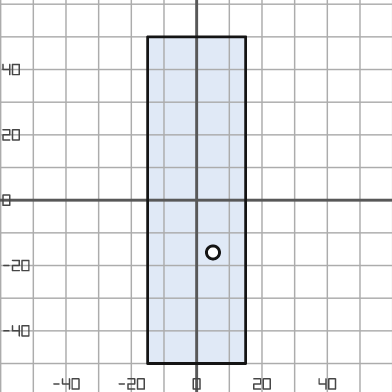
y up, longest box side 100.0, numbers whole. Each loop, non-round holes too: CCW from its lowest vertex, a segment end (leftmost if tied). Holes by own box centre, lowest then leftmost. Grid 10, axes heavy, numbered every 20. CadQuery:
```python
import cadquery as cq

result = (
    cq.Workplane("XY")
    .moveTo(-15.0, -50.0)
    .lineTo(15.0, -50.0)
    .lineTo(15.0, 50.0)
    .lineTo(-15.0, 50.0)
    .close()
    .moveTo(5.0, -16.0)
    .circle(2.0)
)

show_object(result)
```